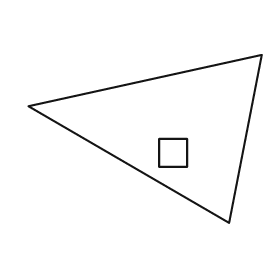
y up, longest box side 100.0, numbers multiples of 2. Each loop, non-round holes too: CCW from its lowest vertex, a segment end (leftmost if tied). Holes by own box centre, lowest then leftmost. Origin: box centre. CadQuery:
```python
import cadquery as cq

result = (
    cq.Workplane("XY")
    .moveTo(36.0, -36.0)
    .lineTo(50.0, 36.0)
    .lineTo(-50.0, 14.0)
    .close()
    .moveTo(6.0, -12.0)
    .lineTo(18.0, -12.0)
    .lineTo(18.0, 0.0)
    .lineTo(6.0, 0.0)
    .close()
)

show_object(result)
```